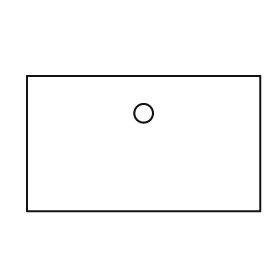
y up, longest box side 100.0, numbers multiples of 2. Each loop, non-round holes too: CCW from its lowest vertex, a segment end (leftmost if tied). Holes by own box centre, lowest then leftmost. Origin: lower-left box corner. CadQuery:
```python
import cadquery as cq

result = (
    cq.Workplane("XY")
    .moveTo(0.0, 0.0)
    .lineTo(100.0, 0.0)
    .lineTo(100.0, 58.0)
    .lineTo(0.0, 58.0)
    .close()
    .moveTo(50.0, 42.0)
    .circle(4.0)
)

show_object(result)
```